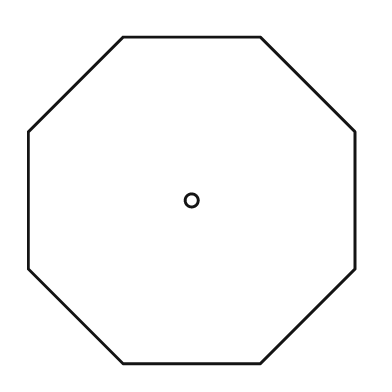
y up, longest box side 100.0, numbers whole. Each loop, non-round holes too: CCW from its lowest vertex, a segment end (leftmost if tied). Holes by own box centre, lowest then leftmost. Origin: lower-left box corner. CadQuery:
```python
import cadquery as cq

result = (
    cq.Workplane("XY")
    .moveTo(29.0, 0.0)
    .lineTo(71.0, 0.0)
    .lineTo(100.0, 29.0)
    .lineTo(100.0, 71.0)
    .lineTo(71.0, 100.0)
    .lineTo(29.0, 100.0)
    .lineTo(0.0, 71.0)
    .lineTo(0.0, 29.0)
    .close()
    .moveTo(50.0, 50.0)
    .circle(2.0)
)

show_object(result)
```